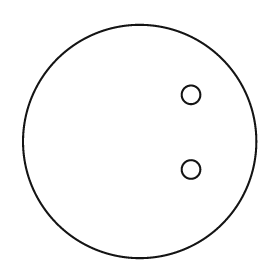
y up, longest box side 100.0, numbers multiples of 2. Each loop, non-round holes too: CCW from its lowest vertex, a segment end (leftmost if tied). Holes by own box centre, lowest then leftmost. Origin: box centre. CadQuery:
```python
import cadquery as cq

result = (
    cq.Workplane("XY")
    .moveTo(0.0, 0.0)
    .circle(50.0)
    .moveTo(22.0, -12.0)
    .circle(4.0)
    .moveTo(22.0, 20.0)
    .circle(4.0)
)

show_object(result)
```